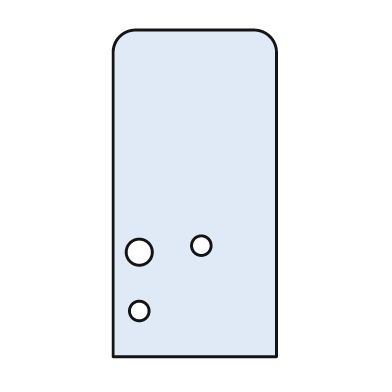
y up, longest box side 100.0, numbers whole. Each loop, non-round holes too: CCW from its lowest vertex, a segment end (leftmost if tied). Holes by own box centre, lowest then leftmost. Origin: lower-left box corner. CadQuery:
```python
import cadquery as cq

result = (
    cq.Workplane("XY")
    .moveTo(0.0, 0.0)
    .lineTo(50.0, 0.0)
    .lineTo(50.0, 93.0)
    .threePointArc((48.0, 98.0), (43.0, 100.0))
    .lineTo(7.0, 100.0)
    .threePointArc((2.0, 98.0), (0.0, 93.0))
    .close()
    .moveTo(8.0, 14.0)
    .circle(3.0)
    .moveTo(8.0, 32.0)
    .circle(4.0)
    .moveTo(27.0, 34.0)
    .circle(3.0)
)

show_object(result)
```